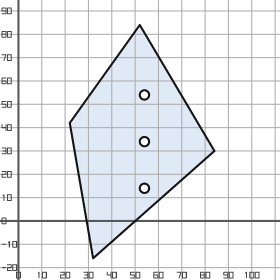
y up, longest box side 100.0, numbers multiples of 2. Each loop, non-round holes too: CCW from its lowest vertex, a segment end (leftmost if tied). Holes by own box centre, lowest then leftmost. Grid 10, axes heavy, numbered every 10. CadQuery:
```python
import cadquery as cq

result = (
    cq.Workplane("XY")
    .moveTo(32.0, -16.0)
    .lineTo(84.0, 30.0)
    .lineTo(52.0, 84.0)
    .lineTo(22.0, 42.0)
    .close()
    .moveTo(54.0, 14.0)
    .circle(2.0)
    .moveTo(54.0, 34.0)
    .circle(2.0)
    .moveTo(54.0, 54.0)
    .circle(2.0)
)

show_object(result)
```